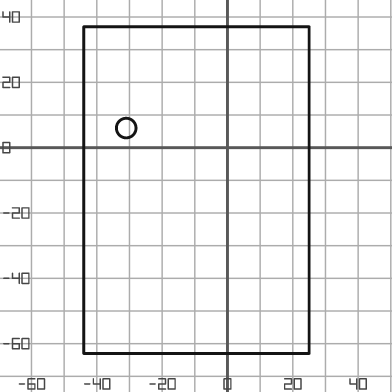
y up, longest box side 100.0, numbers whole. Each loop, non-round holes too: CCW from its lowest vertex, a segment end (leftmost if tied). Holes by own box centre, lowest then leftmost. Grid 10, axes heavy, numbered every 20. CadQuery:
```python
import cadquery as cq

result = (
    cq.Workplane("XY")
    .moveTo(-44.0, -63.0)
    .lineTo(25.0, -63.0)
    .lineTo(25.0, 37.0)
    .lineTo(-44.0, 37.0)
    .close()
    .moveTo(-31.0, 6.0)
    .circle(3.0)
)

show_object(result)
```